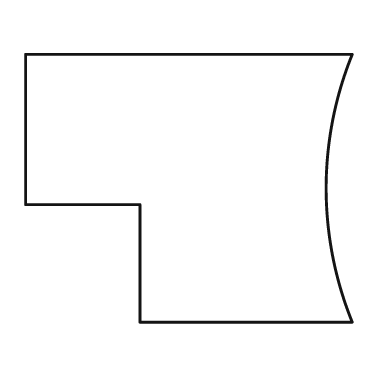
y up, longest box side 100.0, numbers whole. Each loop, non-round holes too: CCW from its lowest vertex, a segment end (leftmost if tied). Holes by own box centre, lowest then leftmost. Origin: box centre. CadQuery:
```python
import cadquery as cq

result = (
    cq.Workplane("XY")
    .moveTo(-15.0, -41.0)
    .lineTo(50.0, -41.0)
    .threePointArc((42.0, 0.0), (50.0, 41.0))
    .lineTo(-50.0, 41.0)
    .lineTo(-50.0, -5.0)
    .lineTo(-15.0, -5.0)
    .close()
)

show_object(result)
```